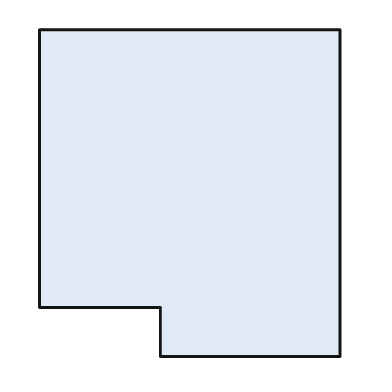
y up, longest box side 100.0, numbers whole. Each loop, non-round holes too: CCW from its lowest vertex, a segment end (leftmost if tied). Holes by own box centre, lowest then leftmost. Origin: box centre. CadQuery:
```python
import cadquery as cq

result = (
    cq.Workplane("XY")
    .moveTo(-9.0, -50.0)
    .lineTo(46.0, -50.0)
    .lineTo(46.0, 50.0)
    .lineTo(-46.0, 50.0)
    .lineTo(-46.0, -35.0)
    .lineTo(-9.0, -35.0)
    .close()
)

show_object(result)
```